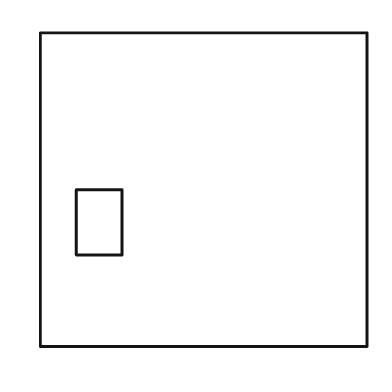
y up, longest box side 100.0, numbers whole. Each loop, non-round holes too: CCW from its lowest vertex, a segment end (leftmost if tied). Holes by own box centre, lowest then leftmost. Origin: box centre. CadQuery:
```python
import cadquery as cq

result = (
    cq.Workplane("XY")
    .moveTo(-50.0, -48.0)
    .lineTo(50.0, -48.0)
    .lineTo(50.0, 48.0)
    .lineTo(-50.0, 48.0)
    .close()
    .moveTo(-39.0, -20.0)
    .lineTo(-25.0, -20.0)
    .lineTo(-25.0, 0.0)
    .lineTo(-39.0, 0.0)
    .close()
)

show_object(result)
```